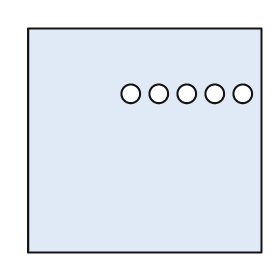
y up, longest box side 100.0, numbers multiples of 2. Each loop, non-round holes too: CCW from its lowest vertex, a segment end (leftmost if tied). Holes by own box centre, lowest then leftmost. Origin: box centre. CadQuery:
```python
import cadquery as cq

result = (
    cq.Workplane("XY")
    .moveTo(-50.0, -48.0)
    .lineTo(50.0, -48.0)
    .lineTo(50.0, 48.0)
    .lineTo(-50.0, 48.0)
    .close()
    .moveTo(-6.0, 20.0)
    .circle(4.0)
    .moveTo(6.0, 20.0)
    .circle(4.0)
    .moveTo(18.0, 20.0)
    .circle(4.0)
    .moveTo(30.0, 20.0)
    .circle(4.0)
    .moveTo(42.0, 20.0)
    .circle(4.0)
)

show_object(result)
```